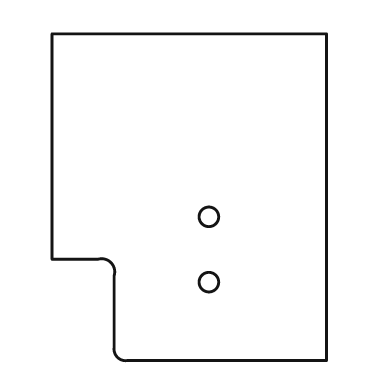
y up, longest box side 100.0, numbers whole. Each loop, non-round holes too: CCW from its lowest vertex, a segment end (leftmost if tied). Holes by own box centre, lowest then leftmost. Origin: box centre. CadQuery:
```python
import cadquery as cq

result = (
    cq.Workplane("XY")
    .moveTo(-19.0, -50.0)
    .lineTo(42.0, -50.0)
    .lineTo(42.0, 50.0)
    .lineTo(-42.0, 50.0)
    .lineTo(-42.0, -19.0)
    .lineTo(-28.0, -19.0)
    .threePointArc((-24.0, -20.0), (-23.0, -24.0))
    .lineTo(-23.0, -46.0)
    .threePointArc((-22.0, -49.0), (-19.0, -50.0))
    .close()
    .moveTo(6.0, -26.0)
    .circle(3.0)
    .moveTo(6.0, -6.0)
    .circle(3.0)
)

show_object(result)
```